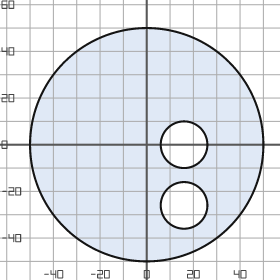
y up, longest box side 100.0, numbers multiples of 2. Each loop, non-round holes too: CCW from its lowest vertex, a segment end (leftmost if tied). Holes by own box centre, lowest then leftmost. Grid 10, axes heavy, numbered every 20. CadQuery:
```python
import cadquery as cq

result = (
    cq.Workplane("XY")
    .moveTo(0.0, 0.0)
    .circle(50.0)
    .moveTo(16.0, -26.0)
    .circle(10.0)
    .moveTo(16.0, 0.0)
    .circle(10.0)
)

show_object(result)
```